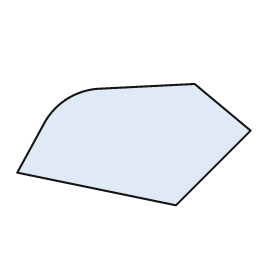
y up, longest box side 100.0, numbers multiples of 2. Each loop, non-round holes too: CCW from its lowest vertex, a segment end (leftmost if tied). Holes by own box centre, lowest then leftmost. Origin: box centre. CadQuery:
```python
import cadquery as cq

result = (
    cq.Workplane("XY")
    .moveTo(18.0, -26.0)
    .lineTo(50.0, 6.0)
    .lineTo(26.0, 26.0)
    .lineTo(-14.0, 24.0)
    .threePointArc((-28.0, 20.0), (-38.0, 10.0))
    .lineTo(-50.0, -12.0)
    .close()
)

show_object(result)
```